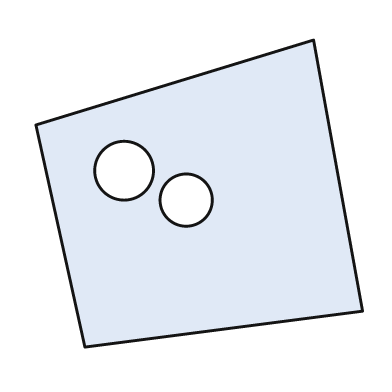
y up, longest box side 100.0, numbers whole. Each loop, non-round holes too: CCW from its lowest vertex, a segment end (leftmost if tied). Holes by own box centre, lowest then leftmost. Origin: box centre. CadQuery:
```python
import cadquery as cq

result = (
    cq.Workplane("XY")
    .moveTo(-35.0, -47.0)
    .lineTo(50.0, -36.0)
    .lineTo(35.0, 47.0)
    .lineTo(-50.0, 21.0)
    .close()
    .moveTo(-4.0, -2.0)
    .circle(8.0)
    .moveTo(-23.0, 7.0)
    .circle(9.0)
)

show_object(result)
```